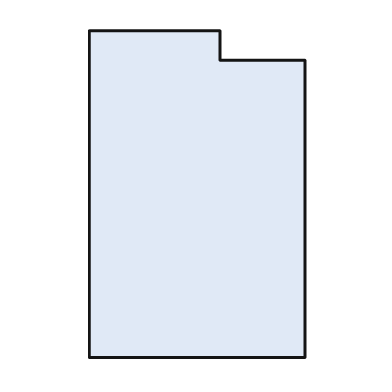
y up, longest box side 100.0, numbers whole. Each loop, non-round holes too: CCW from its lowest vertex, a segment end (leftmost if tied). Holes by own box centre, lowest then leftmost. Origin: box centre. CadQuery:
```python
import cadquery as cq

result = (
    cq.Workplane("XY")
    .moveTo(-33.0, -50.0)
    .lineTo(33.0, -50.0)
    .lineTo(33.0, 41.0)
    .lineTo(7.0, 41.0)
    .lineTo(7.0, 50.0)
    .lineTo(-33.0, 50.0)
    .close()
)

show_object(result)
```